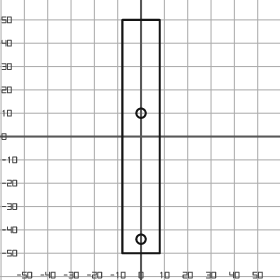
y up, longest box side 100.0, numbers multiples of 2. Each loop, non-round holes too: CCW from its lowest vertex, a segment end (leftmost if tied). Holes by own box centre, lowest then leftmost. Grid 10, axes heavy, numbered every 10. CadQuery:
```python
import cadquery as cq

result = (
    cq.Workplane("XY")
    .moveTo(-8.0, -50.0)
    .lineTo(8.0, -50.0)
    .lineTo(8.0, 50.0)
    .lineTo(-8.0, 50.0)
    .close()
    .moveTo(0.0, -44.0)
    .circle(2.0)
    .moveTo(0.0, 10.0)
    .circle(2.0)
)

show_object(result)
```